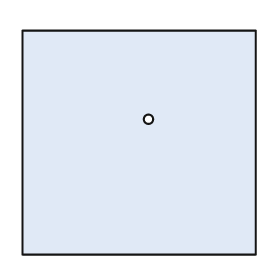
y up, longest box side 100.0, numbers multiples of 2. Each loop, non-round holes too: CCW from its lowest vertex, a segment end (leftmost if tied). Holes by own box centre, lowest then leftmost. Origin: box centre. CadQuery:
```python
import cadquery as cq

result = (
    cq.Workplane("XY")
    .moveTo(-50.0, -48.0)
    .lineTo(50.0, -48.0)
    .lineTo(50.0, 48.0)
    .lineTo(-50.0, 48.0)
    .close()
    .moveTo(4.0, 10.0)
    .circle(2.0)
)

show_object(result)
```